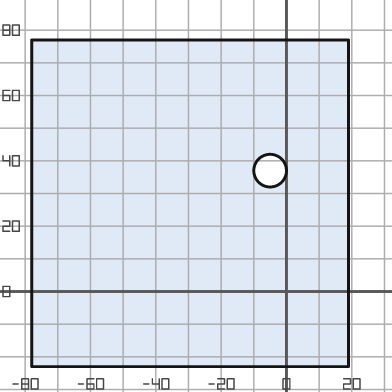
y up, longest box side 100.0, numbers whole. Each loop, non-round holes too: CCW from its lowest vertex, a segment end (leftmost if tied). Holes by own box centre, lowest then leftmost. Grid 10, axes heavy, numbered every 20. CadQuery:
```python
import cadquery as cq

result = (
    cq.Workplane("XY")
    .moveTo(-78.0, -23.0)
    .lineTo(19.0, -23.0)
    .lineTo(19.0, 77.0)
    .lineTo(-78.0, 77.0)
    .close()
    .moveTo(-5.0, 37.0)
    .circle(5.0)
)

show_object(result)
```